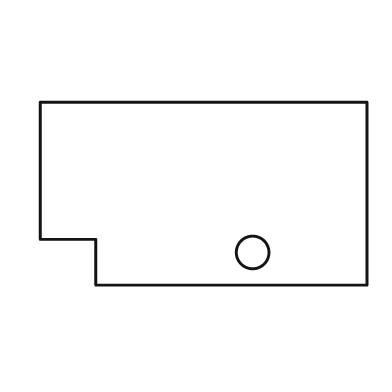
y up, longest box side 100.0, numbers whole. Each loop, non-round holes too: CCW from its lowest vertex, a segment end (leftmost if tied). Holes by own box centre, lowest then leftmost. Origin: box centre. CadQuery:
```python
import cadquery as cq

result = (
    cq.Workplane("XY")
    .moveTo(-33.0, -28.0)
    .lineTo(50.0, -28.0)
    .lineTo(50.0, 28.0)
    .lineTo(-50.0, 28.0)
    .lineTo(-50.0, -14.0)
    .lineTo(-33.0, -14.0)
    .close()
    .moveTo(15.0, -18.0)
    .circle(5.0)
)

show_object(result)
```